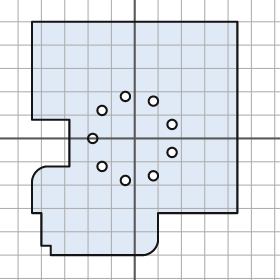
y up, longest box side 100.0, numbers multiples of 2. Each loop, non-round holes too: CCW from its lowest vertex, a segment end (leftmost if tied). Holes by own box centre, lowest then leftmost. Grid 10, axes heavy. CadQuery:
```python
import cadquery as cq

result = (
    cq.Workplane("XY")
    .moveTo(-36.0, -50.0)
    .lineTo(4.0, -50.0)
    .threePointArc((8.0, -48.0), (10.0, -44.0))
    .lineTo(10.0, -32.0)
    .lineTo(44.0, -32.0)
    .lineTo(44.0, 50.0)
    .lineTo(-44.0, 50.0)
    .lineTo(-44.0, 8.0)
    .lineTo(-28.0, 8.0)
    .lineTo(-28.0, -12.0)
    .lineTo(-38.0, -12.0)
    .threePointArc((-42.0, -14.0), (-44.0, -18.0))
    .lineTo(-44.0, -32.0)
    .lineTo(-40.0, -32.0)
    .lineTo(-40.0, -46.0)
    .lineTo(-36.0, -46.0)
    .close()
    .moveTo(-4.0, -18.0)
    .circle(2.0)
    .moveTo(8.0, -16.0)
    .circle(2.0)
    .moveTo(-14.0, -12.0)
    .circle(2.0)
    .moveTo(16.0, -6.0)
    .circle(2.0)
    .moveTo(-18.0, 0.0)
    .circle(2.0)
    .moveTo(16.0, 6.0)
    .circle(2.0)
    .moveTo(-14.0, 12.0)
    .circle(2.0)
    .moveTo(8.0, 16.0)
    .circle(2.0)
    .moveTo(-4.0, 18.0)
    .circle(2.0)
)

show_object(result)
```